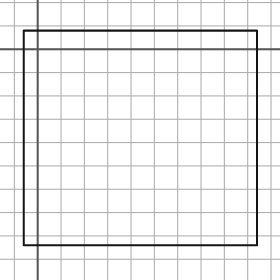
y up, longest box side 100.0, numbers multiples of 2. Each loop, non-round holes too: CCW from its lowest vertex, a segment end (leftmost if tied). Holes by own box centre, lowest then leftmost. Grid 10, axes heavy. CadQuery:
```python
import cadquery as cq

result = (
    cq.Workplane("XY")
    .moveTo(-6.0, -84.0)
    .lineTo(94.0, -84.0)
    .lineTo(94.0, 8.0)
    .lineTo(-6.0, 8.0)
    .close()
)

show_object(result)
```